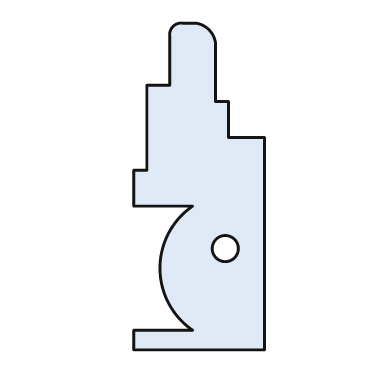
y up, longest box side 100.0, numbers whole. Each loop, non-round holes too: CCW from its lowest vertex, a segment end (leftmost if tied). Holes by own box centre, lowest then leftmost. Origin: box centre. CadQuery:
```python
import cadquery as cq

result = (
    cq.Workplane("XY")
    .moveTo(-20.0, -50.0)
    .lineTo(20.0, -50.0)
    .lineTo(20.0, 15.0)
    .lineTo(9.0, 15.0)
    .lineTo(9.0, 26.0)
    .lineTo(5.0, 26.0)
    .lineTo(5.0, 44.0)
    .threePointArc((3.0, 48.0), (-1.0, 50.0))
    .lineTo(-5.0, 50.0)
    .threePointArc((-8.0, 49.0), (-9.0, 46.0))
    .lineTo(-9.0, 31.0)
    .lineTo(-16.0, 31.0)
    .lineTo(-16.0, 5.0)
    .lineTo(-20.0, 5.0)
    .lineTo(-20.0, -6.0)
    .lineTo(-2.0, -6.0)
    .threePointArc((-12.0, -25.0), (-2.0, -44.0))
    .lineTo(-20.0, -44.0)
    .close()
    .moveTo(8.0, -19.0)
    .circle(4.0)
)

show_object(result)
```